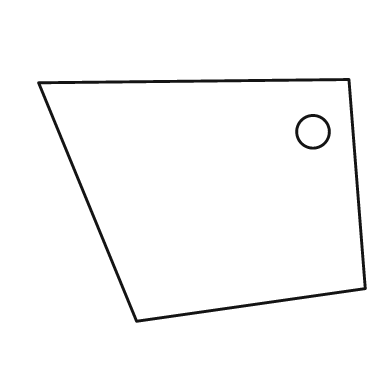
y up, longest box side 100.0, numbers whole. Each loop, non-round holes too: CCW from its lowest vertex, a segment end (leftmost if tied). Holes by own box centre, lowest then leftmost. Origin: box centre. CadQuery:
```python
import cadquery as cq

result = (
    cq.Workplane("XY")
    .moveTo(-20.0, -37.0)
    .lineTo(50.0, -27.0)
    .lineTo(45.0, 37.0)
    .lineTo(-50.0, 36.0)
    .close()
    .moveTo(34.0, 21.0)
    .circle(5.0)
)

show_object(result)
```